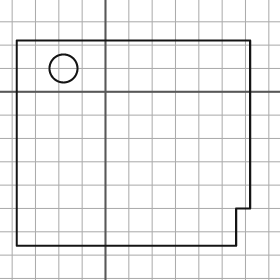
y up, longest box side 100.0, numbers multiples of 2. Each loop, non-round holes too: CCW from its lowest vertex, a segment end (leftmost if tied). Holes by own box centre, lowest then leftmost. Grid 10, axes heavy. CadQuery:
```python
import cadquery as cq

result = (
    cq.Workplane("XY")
    .moveTo(-38.0, -66.0)
    .lineTo(56.0, -66.0)
    .lineTo(56.0, -50.0)
    .lineTo(62.0, -50.0)
    .lineTo(62.0, 22.0)
    .lineTo(-38.0, 22.0)
    .close()
    .moveTo(-18.0, 10.0)
    .circle(6.0)
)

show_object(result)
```